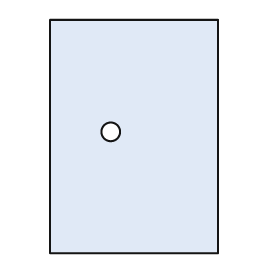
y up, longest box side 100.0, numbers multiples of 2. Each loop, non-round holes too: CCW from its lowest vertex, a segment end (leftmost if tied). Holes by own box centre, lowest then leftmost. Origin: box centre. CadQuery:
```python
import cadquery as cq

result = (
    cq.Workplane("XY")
    .moveTo(-36.0, -50.0)
    .lineTo(36.0, -50.0)
    .lineTo(36.0, 50.0)
    .lineTo(-36.0, 50.0)
    .close()
    .moveTo(-10.0, 2.0)
    .circle(4.0)
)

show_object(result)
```